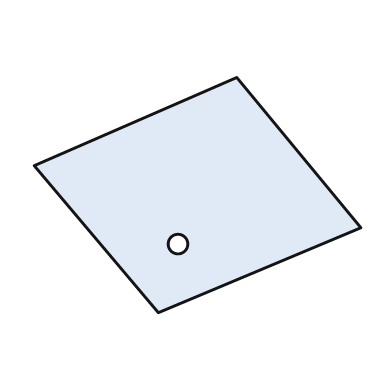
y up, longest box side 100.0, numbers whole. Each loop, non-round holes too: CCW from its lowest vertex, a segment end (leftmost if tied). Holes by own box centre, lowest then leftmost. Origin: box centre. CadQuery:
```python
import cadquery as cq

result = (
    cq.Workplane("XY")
    .moveTo(-12.0, -36.0)
    .lineTo(50.0, -10.0)
    .lineTo(12.0, 36.0)
    .lineTo(-50.0, 9.0)
    .close()
    .moveTo(-6.0, -15.0)
    .circle(3.0)
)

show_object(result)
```